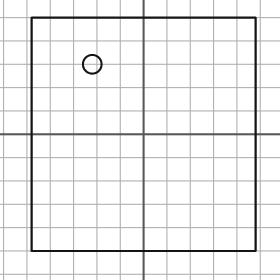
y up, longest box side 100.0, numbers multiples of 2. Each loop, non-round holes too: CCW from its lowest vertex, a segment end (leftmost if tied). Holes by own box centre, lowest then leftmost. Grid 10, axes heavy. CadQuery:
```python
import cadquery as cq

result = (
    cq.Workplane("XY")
    .moveTo(-48.0, -50.0)
    .lineTo(48.0, -50.0)
    .lineTo(48.0, 50.0)
    .lineTo(-48.0, 50.0)
    .close()
    .moveTo(-22.0, 30.0)
    .circle(4.0)
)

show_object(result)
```